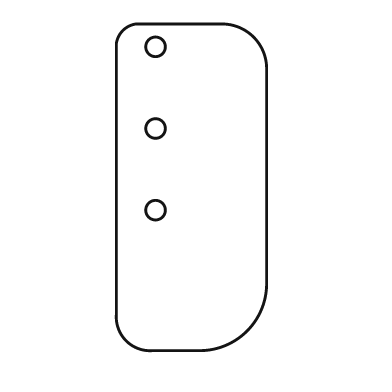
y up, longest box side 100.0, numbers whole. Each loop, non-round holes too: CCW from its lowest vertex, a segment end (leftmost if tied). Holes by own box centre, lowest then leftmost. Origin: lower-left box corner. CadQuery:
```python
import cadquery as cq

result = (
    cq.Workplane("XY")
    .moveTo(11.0, 0.0)
    .lineTo(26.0, 0.0)
    .threePointArc((40.0, 6.0), (46.0, 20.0))
    .lineTo(46.0, 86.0)
    .threePointArc((42.0, 96.0), (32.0, 100.0))
    .lineTo(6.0, 100.0)
    .threePointArc((2.0, 98.0), (0.0, 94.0))
    .lineTo(0.0, 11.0)
    .threePointArc((3.0, 3.0), (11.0, 0.0))
    .close()
    .moveTo(12.0, 43.0)
    .circle(3.0)
    .moveTo(12.0, 68.0)
    .circle(3.0)
    .moveTo(12.0, 93.0)
    .circle(3.0)
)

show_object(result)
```